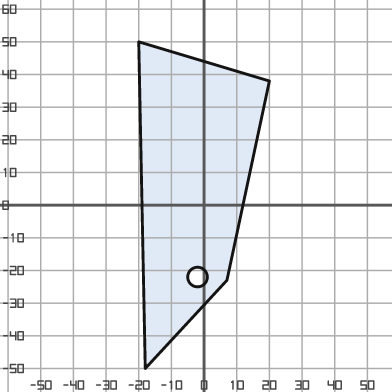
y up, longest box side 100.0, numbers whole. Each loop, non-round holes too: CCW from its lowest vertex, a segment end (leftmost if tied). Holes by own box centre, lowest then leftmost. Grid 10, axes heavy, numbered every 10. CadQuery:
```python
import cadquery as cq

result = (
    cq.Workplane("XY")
    .moveTo(-18.0, -50.0)
    .lineTo(7.0, -23.0)
    .lineTo(20.0, 38.0)
    .lineTo(-20.0, 50.0)
    .close()
    .moveTo(-2.0, -22.0)
    .circle(3.0)
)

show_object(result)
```